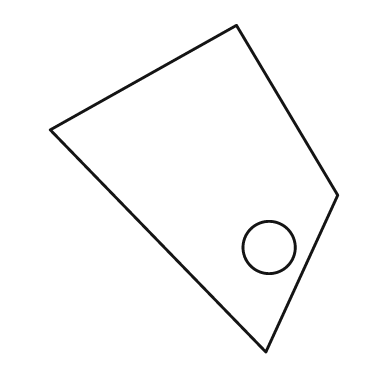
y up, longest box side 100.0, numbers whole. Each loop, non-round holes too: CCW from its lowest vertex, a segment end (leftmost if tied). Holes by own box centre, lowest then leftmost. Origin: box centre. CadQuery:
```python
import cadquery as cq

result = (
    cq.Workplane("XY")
    .moveTo(22.0, -50.0)
    .lineTo(44.0, -2.0)
    .lineTo(13.0, 50.0)
    .lineTo(-44.0, 18.0)
    .close()
    .moveTo(23.0, -18.0)
    .circle(8.0)
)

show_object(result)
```